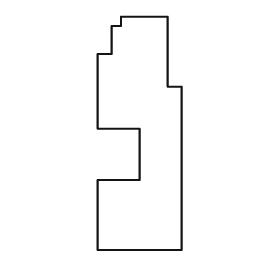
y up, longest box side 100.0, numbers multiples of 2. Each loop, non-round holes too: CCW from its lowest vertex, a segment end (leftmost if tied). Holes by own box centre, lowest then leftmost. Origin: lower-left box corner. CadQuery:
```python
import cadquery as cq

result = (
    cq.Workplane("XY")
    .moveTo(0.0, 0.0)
    .lineTo(36.0, 0.0)
    .lineTo(36.0, 70.0)
    .lineTo(30.0, 70.0)
    .lineTo(30.0, 100.0)
    .lineTo(10.0, 100.0)
    .lineTo(10.0, 96.0)
    .lineTo(6.0, 96.0)
    .lineTo(6.0, 84.0)
    .lineTo(0.0, 84.0)
    .lineTo(0.0, 52.0)
    .lineTo(18.0, 52.0)
    .lineTo(18.0, 30.0)
    .lineTo(0.0, 30.0)
    .close()
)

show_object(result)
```